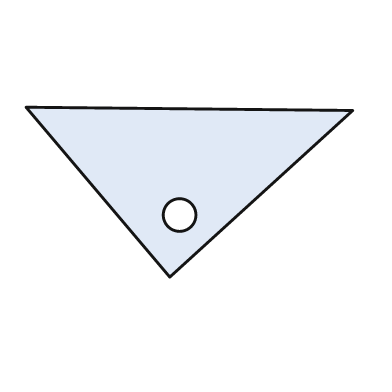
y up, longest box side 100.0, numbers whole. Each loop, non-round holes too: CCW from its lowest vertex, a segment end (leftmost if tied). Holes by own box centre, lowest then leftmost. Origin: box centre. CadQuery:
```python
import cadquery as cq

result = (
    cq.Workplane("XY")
    .moveTo(-6.0, -26.0)
    .lineTo(50.0, 25.0)
    .lineTo(-50.0, 26.0)
    .close()
    .moveTo(-3.0, -7.0)
    .circle(5.0)
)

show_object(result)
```